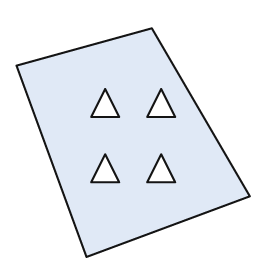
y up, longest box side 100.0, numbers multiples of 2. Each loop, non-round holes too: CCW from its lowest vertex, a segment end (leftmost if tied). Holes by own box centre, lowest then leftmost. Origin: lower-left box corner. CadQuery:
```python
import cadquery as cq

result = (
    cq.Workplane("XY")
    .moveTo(30.0, 0.0)
    .lineTo(100.0, 26.0)
    .lineTo(58.0, 98.0)
    .lineTo(0.0, 82.0)
    .close()
    .moveTo(32.0, 32.0)
    .lineTo(44.0, 32.0)
    .lineTo(38.0, 44.0)
    .close()
    .moveTo(56.0, 32.0)
    .lineTo(68.0, 32.0)
    .lineTo(62.0, 44.0)
    .close()
    .moveTo(32.0, 60.0)
    .lineTo(44.0, 60.0)
    .lineTo(38.0, 72.0)
    .close()
    .moveTo(56.0, 60.0)
    .lineTo(68.0, 60.0)
    .lineTo(62.0, 72.0)
    .close()
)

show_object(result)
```